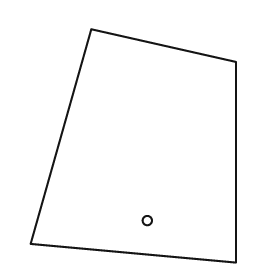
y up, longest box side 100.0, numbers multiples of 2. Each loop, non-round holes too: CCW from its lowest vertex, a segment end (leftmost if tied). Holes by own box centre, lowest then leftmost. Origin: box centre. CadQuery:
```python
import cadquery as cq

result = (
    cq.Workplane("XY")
    .moveTo(44.0, -50.0)
    .lineTo(44.0, 36.0)
    .lineTo(-18.0, 50.0)
    .lineTo(-44.0, -42.0)
    .close()
    .moveTo(6.0, -32.0)
    .circle(2.0)
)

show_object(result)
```